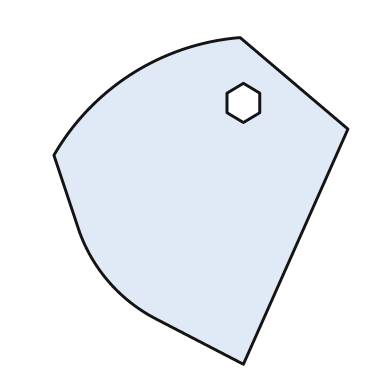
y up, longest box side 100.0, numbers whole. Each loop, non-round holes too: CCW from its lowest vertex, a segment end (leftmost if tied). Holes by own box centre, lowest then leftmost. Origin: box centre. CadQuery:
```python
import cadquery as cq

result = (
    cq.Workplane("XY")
    .moveTo(13.0, -50.0)
    .lineTo(45.0, 22.0)
    .lineTo(12.0, 50.0)
    .threePointArc((-21.0, 39.0), (-45.0, 14.0))
    .lineTo(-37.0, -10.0)
    .threePointArc((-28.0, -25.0), (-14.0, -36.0))
    .close()
    .moveTo(13.0, 24.0)
    .lineTo(18.0, 27.0)
    .lineTo(18.0, 33.0)
    .lineTo(13.0, 36.0)
    .lineTo(8.0, 33.0)
    .lineTo(8.0, 27.0)
    .close()
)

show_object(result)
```